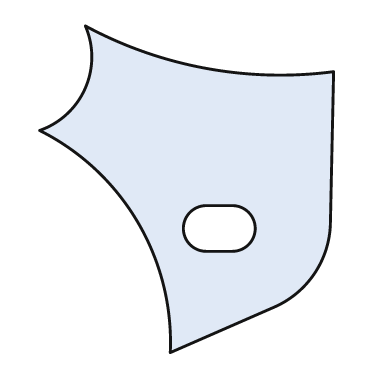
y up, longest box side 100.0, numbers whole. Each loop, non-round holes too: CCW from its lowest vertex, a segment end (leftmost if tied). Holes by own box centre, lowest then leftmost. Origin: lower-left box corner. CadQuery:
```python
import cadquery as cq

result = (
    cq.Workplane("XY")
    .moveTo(40.0, 0.0)
    .lineTo(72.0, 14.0)
    .threePointArc((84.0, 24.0), (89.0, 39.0))
    .lineTo(90.0, 86.0)
    .threePointArc((51.0, 87.0), (14.0, 100.0))
    .threePointArc((14.0, 81.0), (0.0, 68.0))
    .threePointArc((30.0, 40.0), (40.0, 0.0))
    .close()
    .moveTo(51.0, 31.0)
    .lineTo(59.0, 31.0)
    .threePointArc((66.0, 38.0), (59.0, 45.0))
    .lineTo(51.0, 45.0)
    .threePointArc((44.0, 38.0), (51.0, 31.0))
    .close()
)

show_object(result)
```